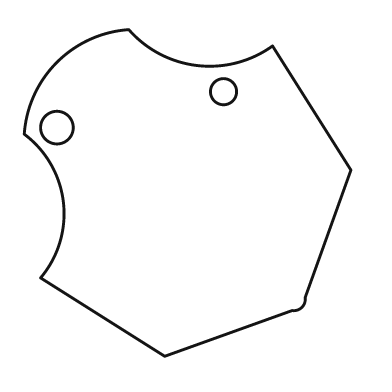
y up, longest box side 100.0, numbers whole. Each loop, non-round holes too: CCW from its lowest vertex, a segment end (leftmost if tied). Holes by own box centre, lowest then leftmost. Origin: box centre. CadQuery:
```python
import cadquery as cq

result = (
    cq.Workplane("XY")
    .moveTo(-7.0, -50.0)
    .lineTo(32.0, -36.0)
    .threePointArc((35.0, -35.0), (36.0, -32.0))
    .lineTo(50.0, 7.0)
    .lineTo(26.0, 45.0)
    .threePointArc((3.0, 39.0), (-18.0, 50.0))
    .threePointArc((-40.0, 40.0), (-50.0, 18.0))
    .threePointArc((-38.0, -3.0), (-45.0, -26.0))
    .close()
    .moveTo(-40.0, 20.0)
    .circle(5.0)
    .moveTo(11.0, 31.0)
    .circle(4.0)
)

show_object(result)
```